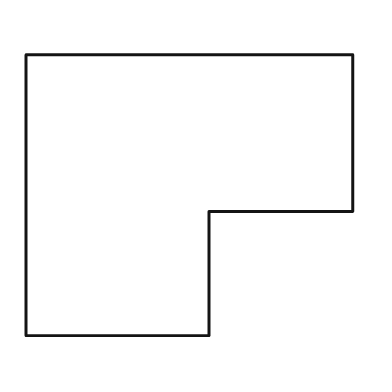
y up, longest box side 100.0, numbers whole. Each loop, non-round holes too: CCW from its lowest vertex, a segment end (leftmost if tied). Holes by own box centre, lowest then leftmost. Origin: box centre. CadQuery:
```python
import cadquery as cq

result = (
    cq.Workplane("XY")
    .moveTo(-50.0, -43.0)
    .lineTo(6.0, -43.0)
    .lineTo(6.0, -5.0)
    .lineTo(50.0, -5.0)
    .lineTo(50.0, 43.0)
    .lineTo(-50.0, 43.0)
    .close()
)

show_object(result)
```